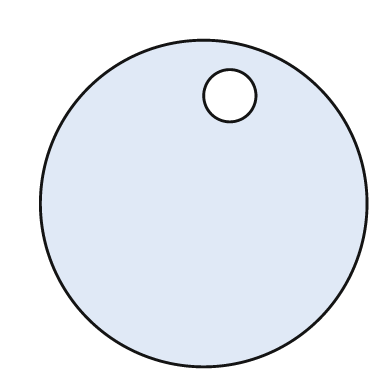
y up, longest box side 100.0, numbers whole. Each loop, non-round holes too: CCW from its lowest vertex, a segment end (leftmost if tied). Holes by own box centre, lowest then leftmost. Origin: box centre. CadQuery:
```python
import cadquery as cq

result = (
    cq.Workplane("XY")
    .moveTo(0.0, 0.0)
    .circle(50.0)
    .moveTo(8.0, 33.0)
    .circle(8.0)
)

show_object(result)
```